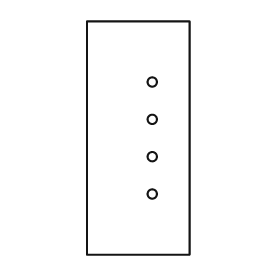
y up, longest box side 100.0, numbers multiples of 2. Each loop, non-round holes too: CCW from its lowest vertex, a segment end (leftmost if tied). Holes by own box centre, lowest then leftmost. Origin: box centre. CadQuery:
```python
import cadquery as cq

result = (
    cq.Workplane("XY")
    .moveTo(-22.0, -50.0)
    .lineTo(22.0, -50.0)
    .lineTo(22.0, 50.0)
    .lineTo(-22.0, 50.0)
    .close()
    .moveTo(6.0, -24.0)
    .circle(2.0)
    .moveTo(6.0, -8.0)
    .circle(2.0)
    .moveTo(6.0, 8.0)
    .circle(2.0)
    .moveTo(6.0, 24.0)
    .circle(2.0)
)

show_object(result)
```